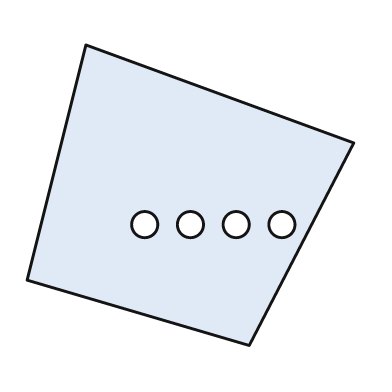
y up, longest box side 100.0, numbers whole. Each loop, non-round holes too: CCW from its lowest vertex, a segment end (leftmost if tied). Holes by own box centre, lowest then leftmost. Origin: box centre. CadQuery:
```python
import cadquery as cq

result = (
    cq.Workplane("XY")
    .moveTo(18.0, -46.0)
    .lineTo(50.0, 16.0)
    .lineTo(-32.0, 46.0)
    .lineTo(-50.0, -26.0)
    .close()
    .moveTo(-14.0, -9.0)
    .circle(4.0)
    .moveTo(0.0, -9.0)
    .circle(4.0)
    .moveTo(14.0, -9.0)
    .circle(4.0)
    .moveTo(28.0, -9.0)
    .circle(4.0)
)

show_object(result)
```